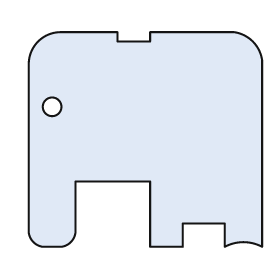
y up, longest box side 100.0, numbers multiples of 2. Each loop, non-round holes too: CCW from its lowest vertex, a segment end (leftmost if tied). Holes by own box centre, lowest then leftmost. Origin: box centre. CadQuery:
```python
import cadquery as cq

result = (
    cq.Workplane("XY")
    .moveTo(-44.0, -46.0)
    .lineTo(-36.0, -46.0)
    .threePointArc((-32.0, -44.0), (-30.0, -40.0))
    .lineTo(-30.0, -18.0)
    .lineTo(2.0, -18.0)
    .lineTo(2.0, -46.0)
    .lineTo(16.0, -46.0)
    .lineTo(16.0, -36.0)
    .lineTo(34.0, -36.0)
    .lineTo(34.0, -46.0)
    .threePointArc((42.0, -44.0), (50.0, -46.0))
    .lineTo(50.0, 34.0)
    .threePointArc((46.0, 42.0), (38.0, 46.0))
    .lineTo(2.0, 46.0)
    .lineTo(2.0, 42.0)
    .lineTo(-12.0, 42.0)
    .lineTo(-12.0, 46.0)
    .lineTo(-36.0, 46.0)
    .threePointArc((-46.0, 42.0), (-50.0, 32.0))
    .lineTo(-50.0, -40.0)
    .threePointArc((-48.0, -44.0), (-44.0, -46.0))
    .close()
    .moveTo(-40.0, 14.0)
    .circle(4.0)
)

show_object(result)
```